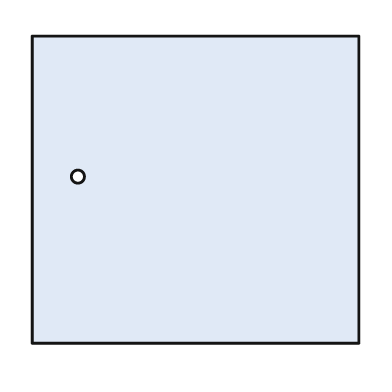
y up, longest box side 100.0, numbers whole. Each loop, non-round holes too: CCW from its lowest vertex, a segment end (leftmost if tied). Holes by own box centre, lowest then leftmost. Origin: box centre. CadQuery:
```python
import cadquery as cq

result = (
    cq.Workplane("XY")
    .moveTo(-50.0, -47.0)
    .lineTo(50.0, -47.0)
    .lineTo(50.0, 47.0)
    .lineTo(-50.0, 47.0)
    .close()
    .moveTo(-36.0, 4.0)
    .circle(2.0)
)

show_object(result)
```